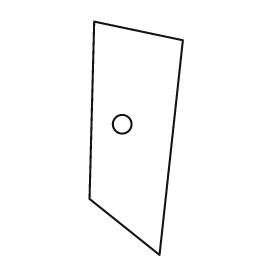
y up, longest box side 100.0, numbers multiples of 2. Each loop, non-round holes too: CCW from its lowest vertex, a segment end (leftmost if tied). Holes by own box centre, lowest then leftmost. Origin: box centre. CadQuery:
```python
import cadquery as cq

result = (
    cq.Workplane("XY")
    .moveTo(10.0, -50.0)
    .lineTo(20.0, 42.0)
    .lineTo(-18.0, 50.0)
    .lineTo(-20.0, -26.0)
    .close()
    .moveTo(-6.0, 6.0)
    .circle(4.0)
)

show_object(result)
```